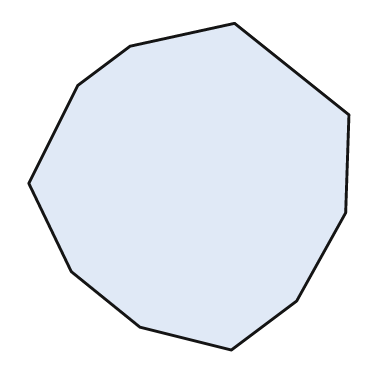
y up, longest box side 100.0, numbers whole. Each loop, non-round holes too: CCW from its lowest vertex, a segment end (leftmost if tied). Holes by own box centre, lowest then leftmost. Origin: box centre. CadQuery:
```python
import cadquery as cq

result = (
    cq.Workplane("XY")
    .moveTo(13.0, -50.0)
    .lineTo(33.0, -35.0)
    .lineTo(48.0, -8.0)
    .lineTo(49.0, 22.0)
    .lineTo(14.0, 50.0)
    .lineTo(-18.0, 43.0)
    .lineTo(-34.0, 31.0)
    .lineTo(-49.0, 1.0)
    .lineTo(-36.0, -26.0)
    .lineTo(-15.0, -43.0)
    .close()
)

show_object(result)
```